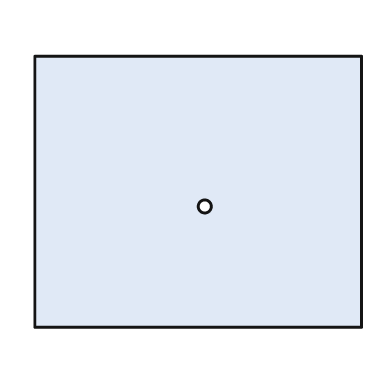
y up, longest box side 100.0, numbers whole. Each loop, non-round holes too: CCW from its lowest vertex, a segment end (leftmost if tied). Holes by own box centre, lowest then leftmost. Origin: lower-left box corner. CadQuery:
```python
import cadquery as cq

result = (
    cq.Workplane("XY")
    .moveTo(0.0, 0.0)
    .lineTo(100.0, 0.0)
    .lineTo(100.0, 83.0)
    .lineTo(0.0, 83.0)
    .close()
    .moveTo(52.0, 37.0)
    .circle(2.0)
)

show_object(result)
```